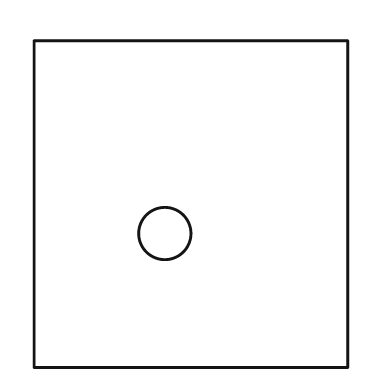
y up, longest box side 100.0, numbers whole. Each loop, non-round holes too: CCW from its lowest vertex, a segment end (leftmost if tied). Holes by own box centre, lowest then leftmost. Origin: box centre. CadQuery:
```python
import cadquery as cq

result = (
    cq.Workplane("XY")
    .moveTo(-48.0, -50.0)
    .lineTo(48.0, -50.0)
    .lineTo(48.0, 50.0)
    .lineTo(-48.0, 50.0)
    .close()
    .moveTo(-8.0, -9.0)
    .circle(8.0)
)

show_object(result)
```